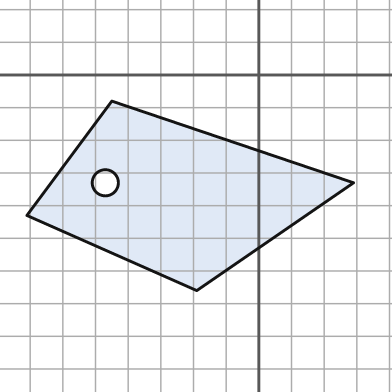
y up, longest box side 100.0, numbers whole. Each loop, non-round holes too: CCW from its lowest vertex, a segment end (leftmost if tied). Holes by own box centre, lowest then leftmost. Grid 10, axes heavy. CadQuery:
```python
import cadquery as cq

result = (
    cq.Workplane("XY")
    .moveTo(-19.0, -66.0)
    .lineTo(29.0, -33.0)
    .lineTo(-45.0, -8.0)
    .lineTo(-71.0, -43.0)
    .close()
    .moveTo(-47.0, -33.0)
    .circle(4.0)
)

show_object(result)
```